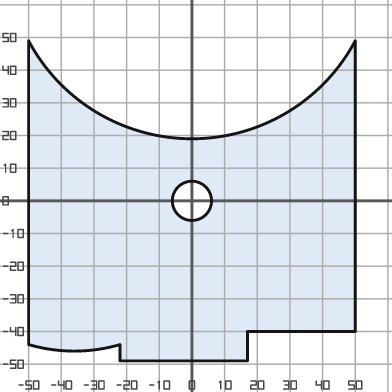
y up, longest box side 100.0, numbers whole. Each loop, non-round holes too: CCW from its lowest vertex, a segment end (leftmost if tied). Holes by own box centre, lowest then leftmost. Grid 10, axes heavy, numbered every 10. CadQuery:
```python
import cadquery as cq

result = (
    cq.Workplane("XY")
    .moveTo(-22.0, -49.0)
    .lineTo(17.0, -49.0)
    .lineTo(17.0, -40.0)
    .lineTo(50.0, -40.0)
    .lineTo(50.0, 49.0)
    .threePointArc((0.0, 19.0), (-50.0, 49.0))
    .lineTo(-50.0, -44.0)
    .threePointArc((-36.0, -46.0), (-22.0, -44.0))
    .close()
    .moveTo(0.0, 0.0)
    .circle(6.0)
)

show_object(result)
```